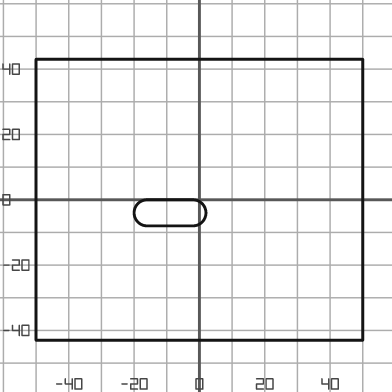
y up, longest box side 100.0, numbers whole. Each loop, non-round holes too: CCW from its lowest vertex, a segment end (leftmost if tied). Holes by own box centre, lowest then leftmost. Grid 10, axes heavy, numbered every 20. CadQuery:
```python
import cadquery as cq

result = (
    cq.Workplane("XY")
    .moveTo(-50.0, -43.0)
    .lineTo(50.0, -43.0)
    .lineTo(50.0, 43.0)
    .lineTo(-50.0, 43.0)
    .close()
    .moveTo(-16.0, -8.0)
    .lineTo(-2.0, -8.0)
    .threePointArc((2.0, -4.0), (-2.0, 0.0))
    .lineTo(-16.0, 0.0)
    .threePointArc((-20.0, -4.0), (-16.0, -8.0))
    .close()
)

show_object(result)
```